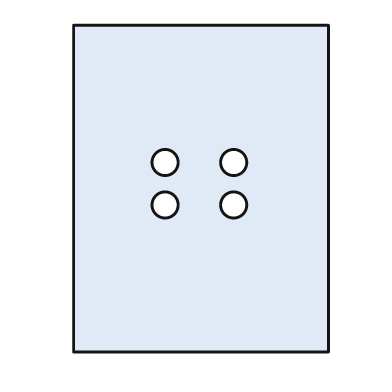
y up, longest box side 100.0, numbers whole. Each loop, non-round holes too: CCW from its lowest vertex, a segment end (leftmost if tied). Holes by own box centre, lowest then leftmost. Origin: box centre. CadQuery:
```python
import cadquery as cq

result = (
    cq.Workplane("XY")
    .moveTo(-39.0, -50.0)
    .lineTo(39.0, -50.0)
    .lineTo(39.0, 50.0)
    .lineTo(-39.0, 50.0)
    .close()
    .moveTo(-11.0, -5.0)
    .circle(4.0)
    .moveTo(10.0, -5.0)
    .circle(4.0)
    .moveTo(-11.0, 8.0)
    .circle(4.0)
    .moveTo(10.0, 8.0)
    .circle(4.0)
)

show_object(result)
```